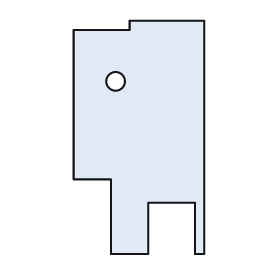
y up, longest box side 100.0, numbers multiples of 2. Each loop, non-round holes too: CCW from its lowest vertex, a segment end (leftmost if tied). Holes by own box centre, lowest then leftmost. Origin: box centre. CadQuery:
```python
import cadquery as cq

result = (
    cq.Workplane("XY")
    .moveTo(-12.0, -50.0)
    .lineTo(4.0, -50.0)
    .lineTo(4.0, -28.0)
    .lineTo(24.0, -28.0)
    .lineTo(24.0, -50.0)
    .lineTo(28.0, -50.0)
    .lineTo(28.0, 50.0)
    .lineTo(-4.0, 50.0)
    .lineTo(-4.0, 46.0)
    .lineTo(-28.0, 46.0)
    .lineTo(-28.0, -18.0)
    .lineTo(-12.0, -18.0)
    .close()
    .moveTo(-10.0, 24.0)
    .circle(4.0)
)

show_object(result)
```